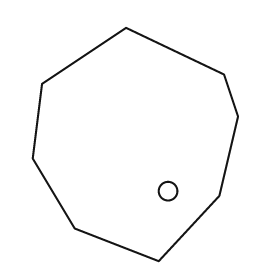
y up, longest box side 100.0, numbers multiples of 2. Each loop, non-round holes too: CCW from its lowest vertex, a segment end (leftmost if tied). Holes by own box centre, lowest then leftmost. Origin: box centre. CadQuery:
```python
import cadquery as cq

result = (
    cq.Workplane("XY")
    .moveTo(10.0, -50.0)
    .lineTo(36.0, -22.0)
    .lineTo(44.0, 12.0)
    .lineTo(38.0, 30.0)
    .lineTo(-4.0, 50.0)
    .lineTo(-40.0, 26.0)
    .lineTo(-44.0, -6.0)
    .lineTo(-26.0, -36.0)
    .close()
    .moveTo(14.0, -20.0)
    .circle(4.0)
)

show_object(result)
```